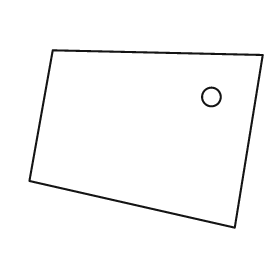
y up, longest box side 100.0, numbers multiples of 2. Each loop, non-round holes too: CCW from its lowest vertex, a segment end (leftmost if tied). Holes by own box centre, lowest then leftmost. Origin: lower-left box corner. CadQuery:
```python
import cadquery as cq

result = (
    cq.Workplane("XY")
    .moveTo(88.0, 0.0)
    .lineTo(100.0, 74.0)
    .lineTo(10.0, 76.0)
    .lineTo(0.0, 20.0)
    .close()
    .moveTo(78.0, 56.0)
    .circle(4.0)
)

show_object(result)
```